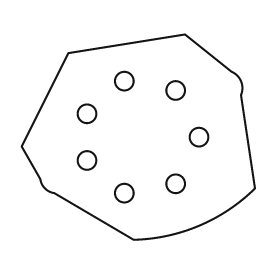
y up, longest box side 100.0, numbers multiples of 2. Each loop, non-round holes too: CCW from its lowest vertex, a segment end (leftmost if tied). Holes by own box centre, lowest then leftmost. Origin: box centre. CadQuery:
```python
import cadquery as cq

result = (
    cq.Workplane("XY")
    .moveTo(-2.0, -44.0)
    .threePointArc((26.0, -38.0), (50.0, -22.0))
    .lineTo(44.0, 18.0)
    .threePointArc((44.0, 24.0), (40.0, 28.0))
    .lineTo(20.0, 44.0)
    .lineTo(-30.0, 36.0)
    .lineTo(-50.0, -4.0)
    .lineTo(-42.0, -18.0)
    .threePointArc((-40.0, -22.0), (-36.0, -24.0))
    .close()
    .moveTo(-6.0, -24.0)
    .circle(4.0)
    .moveTo(16.0, -20.0)
    .circle(4.0)
    .moveTo(-22.0, -10.0)
    .circle(4.0)
    .moveTo(26.0, 0.0)
    .circle(4.0)
    .moveTo(-22.0, 10.0)
    .circle(4.0)
    .moveTo(16.0, 20.0)
    .circle(4.0)
    .moveTo(-6.0, 24.0)
    .circle(4.0)
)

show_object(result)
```